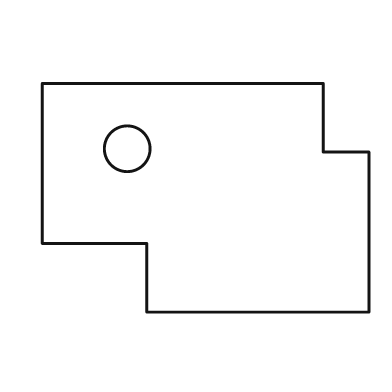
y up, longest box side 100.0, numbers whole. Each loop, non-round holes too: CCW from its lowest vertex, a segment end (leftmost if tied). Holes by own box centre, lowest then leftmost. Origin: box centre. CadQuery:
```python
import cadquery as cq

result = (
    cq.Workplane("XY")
    .moveTo(-18.0, -35.0)
    .lineTo(50.0, -35.0)
    .lineTo(50.0, 14.0)
    .lineTo(36.0, 14.0)
    .lineTo(36.0, 35.0)
    .lineTo(-50.0, 35.0)
    .lineTo(-50.0, -14.0)
    .lineTo(-18.0, -14.0)
    .close()
    .moveTo(-24.0, 15.0)
    .circle(7.0)
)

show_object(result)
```